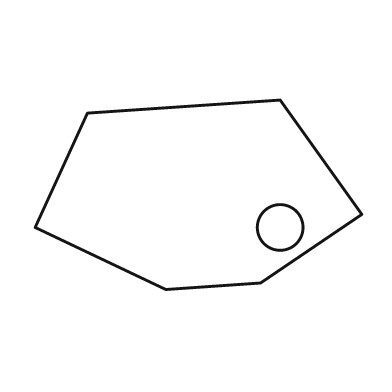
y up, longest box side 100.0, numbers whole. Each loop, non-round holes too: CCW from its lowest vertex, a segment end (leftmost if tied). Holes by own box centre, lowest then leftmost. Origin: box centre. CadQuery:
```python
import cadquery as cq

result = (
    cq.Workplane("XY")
    .moveTo(-10.0, -29.0)
    .lineTo(19.0, -27.0)
    .lineTo(50.0, -6.0)
    .lineTo(25.0, 29.0)
    .lineTo(-34.0, 25.0)
    .lineTo(-50.0, -10.0)
    .close()
    .moveTo(25.0, -10.0)
    .circle(7.0)
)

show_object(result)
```